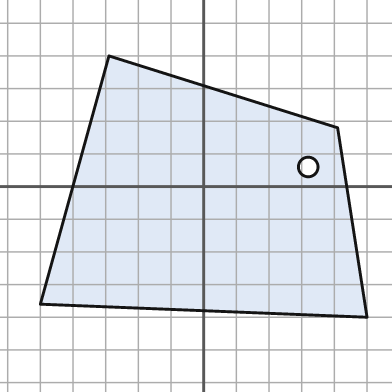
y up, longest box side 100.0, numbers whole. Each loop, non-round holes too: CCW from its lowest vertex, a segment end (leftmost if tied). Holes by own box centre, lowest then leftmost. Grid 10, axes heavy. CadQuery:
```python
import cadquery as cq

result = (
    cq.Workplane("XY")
    .moveTo(50.0, -40.0)
    .lineTo(41.0, 18.0)
    .lineTo(-29.0, 40.0)
    .lineTo(-50.0, -36.0)
    .close()
    .moveTo(32.0, 6.0)
    .circle(3.0)
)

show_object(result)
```